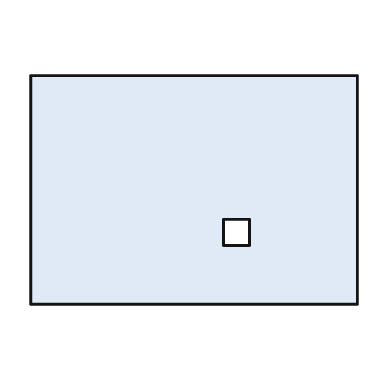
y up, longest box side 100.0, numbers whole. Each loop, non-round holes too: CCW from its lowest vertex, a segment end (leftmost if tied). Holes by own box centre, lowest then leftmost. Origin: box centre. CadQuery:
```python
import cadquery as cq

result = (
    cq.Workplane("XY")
    .moveTo(-50.0, -35.0)
    .lineTo(50.0, -35.0)
    .lineTo(50.0, 35.0)
    .lineTo(-50.0, 35.0)
    .close()
    .moveTo(9.0, -17.0)
    .lineTo(17.0, -17.0)
    .lineTo(17.0, -9.0)
    .lineTo(9.0, -9.0)
    .close()
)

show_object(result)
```